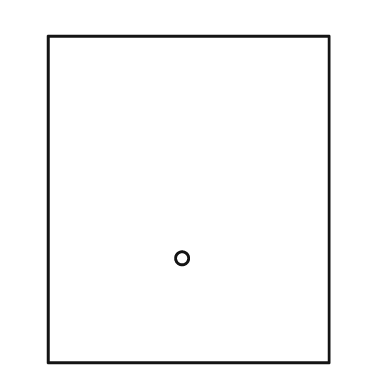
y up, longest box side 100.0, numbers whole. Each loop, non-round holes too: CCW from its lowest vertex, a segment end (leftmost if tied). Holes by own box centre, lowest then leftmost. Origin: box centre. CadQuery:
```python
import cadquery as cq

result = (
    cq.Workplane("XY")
    .moveTo(-43.0, -50.0)
    .lineTo(43.0, -50.0)
    .lineTo(43.0, 50.0)
    .lineTo(-43.0, 50.0)
    .close()
    .moveTo(-2.0, -18.0)
    .circle(2.0)
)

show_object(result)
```